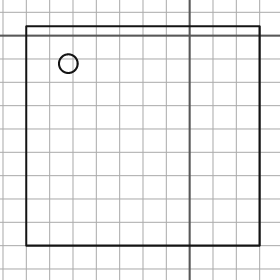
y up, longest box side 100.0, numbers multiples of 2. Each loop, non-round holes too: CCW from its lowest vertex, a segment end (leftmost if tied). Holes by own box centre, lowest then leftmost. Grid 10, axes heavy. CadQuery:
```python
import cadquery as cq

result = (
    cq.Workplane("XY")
    .moveTo(-70.0, -90.0)
    .lineTo(30.0, -90.0)
    .lineTo(30.0, 4.0)
    .lineTo(-70.0, 4.0)
    .close()
    .moveTo(-52.0, -12.0)
    .circle(4.0)
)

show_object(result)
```